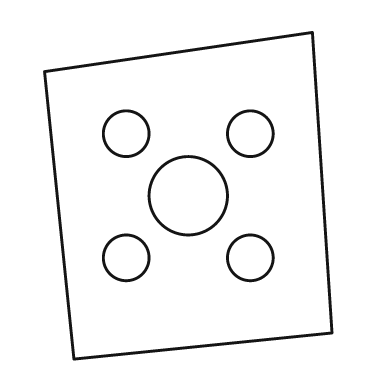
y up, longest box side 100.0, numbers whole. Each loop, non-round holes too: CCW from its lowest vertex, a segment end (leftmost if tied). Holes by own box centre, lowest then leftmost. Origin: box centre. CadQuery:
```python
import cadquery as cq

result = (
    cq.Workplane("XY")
    .moveTo(-35.0, -50.0)
    .lineTo(44.0, -42.0)
    .lineTo(38.0, 50.0)
    .lineTo(-44.0, 38.0)
    .close()
    .moveTo(-19.0, -19.0)
    .circle(7.0)
    .moveTo(19.0, -19.0)
    .circle(7.0)
    .moveTo(0.0, 0.0)
    .circle(12.0)
    .moveTo(-19.0, 19.0)
    .circle(7.0)
    .moveTo(19.0, 19.0)
    .circle(7.0)
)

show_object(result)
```